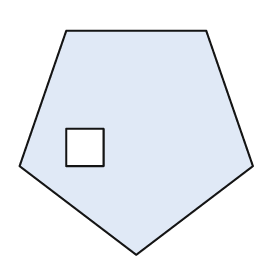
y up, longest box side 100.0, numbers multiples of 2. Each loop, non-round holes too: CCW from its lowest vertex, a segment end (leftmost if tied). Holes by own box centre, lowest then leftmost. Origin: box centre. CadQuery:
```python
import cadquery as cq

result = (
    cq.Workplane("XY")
    .moveTo(0.0, -48.0)
    .lineTo(50.0, -10.0)
    .lineTo(30.0, 48.0)
    .lineTo(-30.0, 48.0)
    .lineTo(-50.0, -10.0)
    .close()
    .moveTo(-30.0, -10.0)
    .lineTo(-14.0, -10.0)
    .lineTo(-14.0, 6.0)
    .lineTo(-30.0, 6.0)
    .close()
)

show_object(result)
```